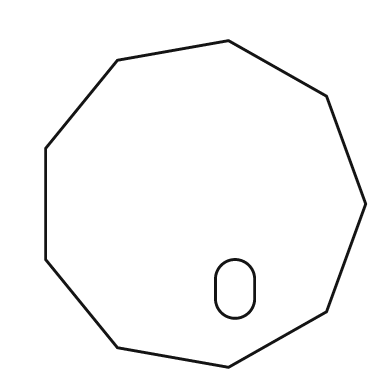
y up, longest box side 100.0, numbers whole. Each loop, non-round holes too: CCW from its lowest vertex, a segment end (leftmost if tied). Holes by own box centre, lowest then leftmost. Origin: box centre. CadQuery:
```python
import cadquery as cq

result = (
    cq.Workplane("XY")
    .moveTo(7.0, -50.0)
    .lineTo(37.0, -33.0)
    .lineTo(49.0, 0.0)
    .lineTo(37.0, 33.0)
    .lineTo(7.0, 50.0)
    .lineTo(-27.0, 44.0)
    .lineTo(-49.0, 17.0)
    .lineTo(-49.0, -17.0)
    .lineTo(-27.0, -44.0)
    .close()
    .moveTo(3.0, -29.0)
    .threePointArc((9.0, -35.0), (15.0, -29.0))
    .lineTo(15.0, -23.0)
    .threePointArc((9.0, -17.0), (3.0, -23.0))
    .close()
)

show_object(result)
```